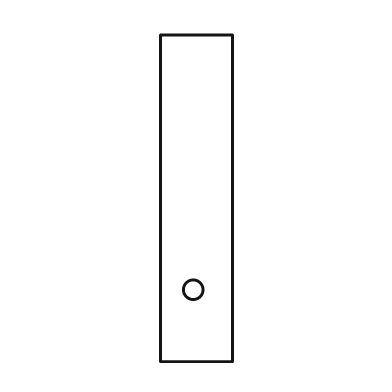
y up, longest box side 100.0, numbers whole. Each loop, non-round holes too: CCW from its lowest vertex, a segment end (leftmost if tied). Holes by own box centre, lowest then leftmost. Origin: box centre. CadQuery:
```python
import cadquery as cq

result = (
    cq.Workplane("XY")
    .moveTo(-11.0, -50.0)
    .lineTo(11.0, -50.0)
    .lineTo(11.0, 50.0)
    .lineTo(-11.0, 50.0)
    .close()
    .moveTo(-1.0, -28.0)
    .circle(3.0)
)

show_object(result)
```